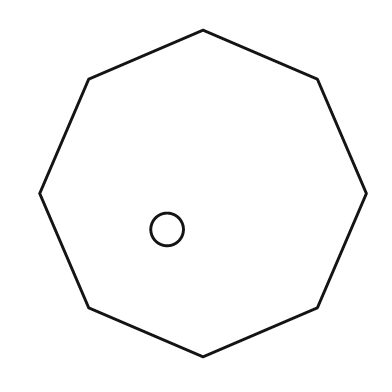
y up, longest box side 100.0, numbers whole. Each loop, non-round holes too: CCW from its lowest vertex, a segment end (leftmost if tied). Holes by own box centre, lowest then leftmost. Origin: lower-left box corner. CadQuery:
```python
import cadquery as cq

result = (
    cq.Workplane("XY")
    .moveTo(50.0, 0.0)
    .lineTo(85.0, 15.0)
    .lineTo(100.0, 50.0)
    .lineTo(85.0, 85.0)
    .lineTo(50.0, 100.0)
    .lineTo(15.0, 85.0)
    .lineTo(0.0, 50.0)
    .lineTo(15.0, 15.0)
    .close()
    .moveTo(39.0, 39.0)
    .circle(5.0)
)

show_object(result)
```